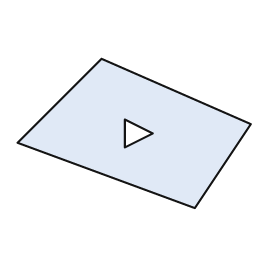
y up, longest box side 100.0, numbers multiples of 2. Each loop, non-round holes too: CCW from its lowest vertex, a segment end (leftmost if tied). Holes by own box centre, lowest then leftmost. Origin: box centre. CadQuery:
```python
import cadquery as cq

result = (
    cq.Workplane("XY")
    .moveTo(26.0, -32.0)
    .lineTo(50.0, 4.0)
    .lineTo(-14.0, 32.0)
    .lineTo(-50.0, -4.0)
    .close()
    .moveTo(-4.0, -6.0)
    .lineTo(8.0, 0.0)
    .lineTo(-4.0, 6.0)
    .close()
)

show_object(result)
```